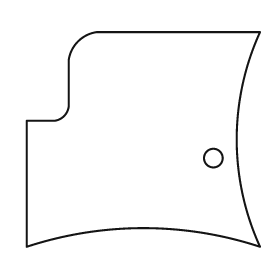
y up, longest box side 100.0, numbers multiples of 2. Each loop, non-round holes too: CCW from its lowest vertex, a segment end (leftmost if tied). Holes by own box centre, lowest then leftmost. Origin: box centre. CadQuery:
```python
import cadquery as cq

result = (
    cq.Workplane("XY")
    .moveTo(-50.0, -46.0)
    .threePointArc((0.0, -38.0), (50.0, -46.0))
    .threePointArc((40.0, 0.0), (50.0, 46.0))
    .lineTo(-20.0, 46.0)
    .threePointArc((-28.0, 42.0), (-32.0, 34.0))
    .lineTo(-32.0, 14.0)
    .threePointArc((-34.0, 10.0), (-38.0, 8.0))
    .lineTo(-50.0, 8.0)
    .close()
    .moveTo(30.0, -8.0)
    .circle(4.0)
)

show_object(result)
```